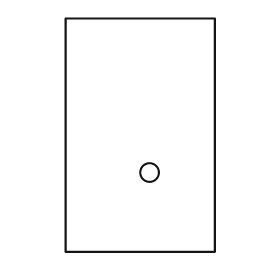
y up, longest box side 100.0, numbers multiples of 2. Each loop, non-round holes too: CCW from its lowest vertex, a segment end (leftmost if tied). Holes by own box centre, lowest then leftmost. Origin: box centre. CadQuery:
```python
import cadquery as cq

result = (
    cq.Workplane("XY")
    .moveTo(-32.0, -50.0)
    .lineTo(32.0, -50.0)
    .lineTo(32.0, 50.0)
    .lineTo(-32.0, 50.0)
    .close()
    .moveTo(4.0, -16.0)
    .circle(4.0)
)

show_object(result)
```